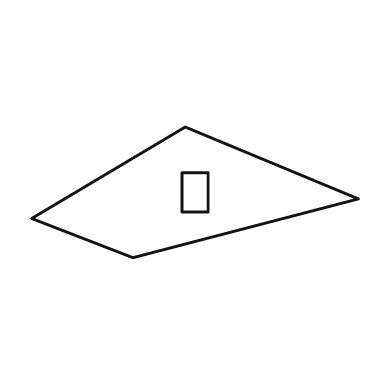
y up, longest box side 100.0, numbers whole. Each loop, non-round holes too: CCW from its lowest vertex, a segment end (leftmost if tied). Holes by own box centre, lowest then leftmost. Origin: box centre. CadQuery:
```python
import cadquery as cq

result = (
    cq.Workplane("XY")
    .moveTo(-19.0, -20.0)
    .lineTo(50.0, -2.0)
    .lineTo(-3.0, 20.0)
    .lineTo(-50.0, -8.0)
    .close()
    .moveTo(-4.0, -6.0)
    .lineTo(4.0, -6.0)
    .lineTo(4.0, 6.0)
    .lineTo(-4.0, 6.0)
    .close()
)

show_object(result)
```